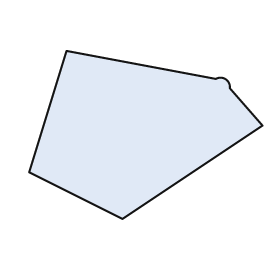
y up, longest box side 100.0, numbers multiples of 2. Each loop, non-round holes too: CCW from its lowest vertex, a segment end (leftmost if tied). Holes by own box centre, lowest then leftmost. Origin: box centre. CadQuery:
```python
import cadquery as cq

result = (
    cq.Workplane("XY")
    .moveTo(-10.0, -36.0)
    .lineTo(50.0, 4.0)
    .lineTo(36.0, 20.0)
    .threePointArc((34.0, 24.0), (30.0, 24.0))
    .lineTo(-34.0, 36.0)
    .lineTo(-50.0, -16.0)
    .close()
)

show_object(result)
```